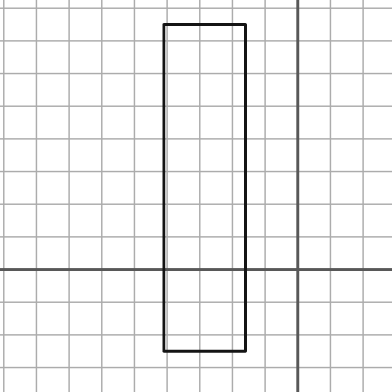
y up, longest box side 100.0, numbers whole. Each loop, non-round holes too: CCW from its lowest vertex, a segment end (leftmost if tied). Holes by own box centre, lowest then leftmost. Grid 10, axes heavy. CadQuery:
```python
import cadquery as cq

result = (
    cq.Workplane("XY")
    .moveTo(-41.0, -25.0)
    .lineTo(-16.0, -25.0)
    .lineTo(-16.0, 75.0)
    .lineTo(-41.0, 75.0)
    .close()
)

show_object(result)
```